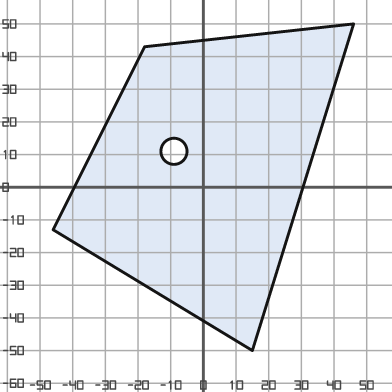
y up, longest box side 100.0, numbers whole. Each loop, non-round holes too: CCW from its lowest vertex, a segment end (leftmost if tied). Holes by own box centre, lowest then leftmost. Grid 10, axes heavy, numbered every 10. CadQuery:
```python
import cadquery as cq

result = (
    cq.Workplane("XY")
    .moveTo(15.0, -50.0)
    .lineTo(46.0, 50.0)
    .lineTo(-18.0, 43.0)
    .lineTo(-46.0, -13.0)
    .close()
    .moveTo(-9.0, 11.0)
    .circle(4.0)
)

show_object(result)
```